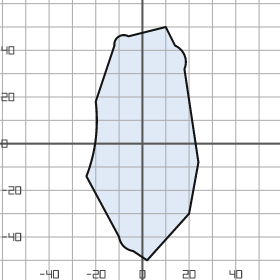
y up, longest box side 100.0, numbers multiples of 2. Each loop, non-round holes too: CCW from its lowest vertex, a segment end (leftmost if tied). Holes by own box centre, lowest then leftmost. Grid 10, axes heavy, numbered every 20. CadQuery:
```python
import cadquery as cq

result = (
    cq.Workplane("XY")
    .moveTo(2.0, -50.0)
    .lineTo(20.0, -30.0)
    .lineTo(24.0, -8.0)
    .lineTo(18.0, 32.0)
    .threePointArc((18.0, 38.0), (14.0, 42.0))
    .lineTo(10.0, 50.0)
    .lineTo(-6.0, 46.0)
    .threePointArc((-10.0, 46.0), (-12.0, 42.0))
    .lineTo(-20.0, 18.0)
    .threePointArc((-20.0, 2.0), (-24.0, -14.0))
    .lineTo(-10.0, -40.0)
    .threePointArc((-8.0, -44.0), (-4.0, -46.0))
    .close()
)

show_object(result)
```